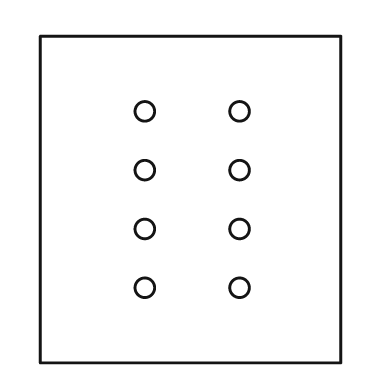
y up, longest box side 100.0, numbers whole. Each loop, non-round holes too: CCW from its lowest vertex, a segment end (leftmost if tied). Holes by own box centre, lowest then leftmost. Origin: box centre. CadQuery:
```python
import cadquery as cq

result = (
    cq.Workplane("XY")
    .moveTo(-46.0, -50.0)
    .lineTo(46.0, -50.0)
    .lineTo(46.0, 50.0)
    .lineTo(-46.0, 50.0)
    .close()
    .moveTo(-14.0, -27.0)
    .circle(3.0)
    .moveTo(15.0, -27.0)
    .circle(3.0)
    .moveTo(-14.0, -9.0)
    .circle(3.0)
    .moveTo(15.0, -9.0)
    .circle(3.0)
    .moveTo(-14.0, 9.0)
    .circle(3.0)
    .moveTo(15.0, 9.0)
    .circle(3.0)
    .moveTo(-14.0, 27.0)
    .circle(3.0)
    .moveTo(15.0, 27.0)
    .circle(3.0)
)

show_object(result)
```